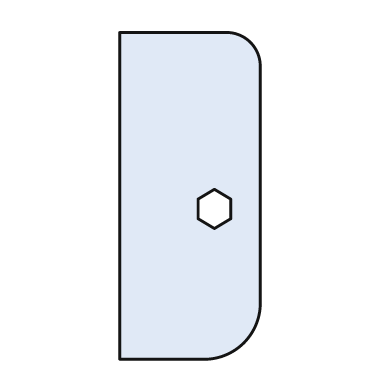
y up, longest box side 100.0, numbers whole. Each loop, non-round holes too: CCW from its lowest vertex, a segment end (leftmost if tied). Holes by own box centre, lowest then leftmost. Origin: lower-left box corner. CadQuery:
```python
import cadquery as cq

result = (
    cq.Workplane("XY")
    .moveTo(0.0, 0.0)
    .lineTo(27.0, 0.0)
    .threePointArc((38.0, 5.0), (43.0, 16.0))
    .lineTo(43.0, 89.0)
    .threePointArc((40.0, 97.0), (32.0, 100.0))
    .lineTo(0.0, 100.0)
    .close()
    .moveTo(29.0, 40.0)
    .lineTo(34.0, 43.0)
    .lineTo(34.0, 49.0)
    .lineTo(29.0, 52.0)
    .lineTo(24.0, 49.0)
    .lineTo(24.0, 43.0)
    .close()
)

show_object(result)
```